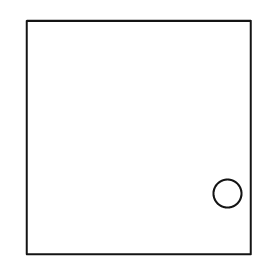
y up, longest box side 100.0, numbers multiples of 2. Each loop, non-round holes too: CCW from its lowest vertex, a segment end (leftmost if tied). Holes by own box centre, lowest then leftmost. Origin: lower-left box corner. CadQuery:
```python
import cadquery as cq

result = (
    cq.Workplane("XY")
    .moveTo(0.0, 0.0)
    .lineTo(96.0, 0.0)
    .lineTo(96.0, 100.0)
    .lineTo(0.0, 100.0)
    .close()
    .moveTo(86.0, 26.0)
    .circle(6.0)
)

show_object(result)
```